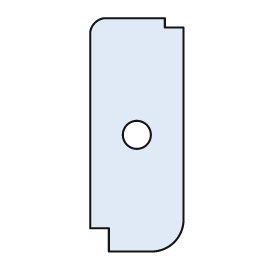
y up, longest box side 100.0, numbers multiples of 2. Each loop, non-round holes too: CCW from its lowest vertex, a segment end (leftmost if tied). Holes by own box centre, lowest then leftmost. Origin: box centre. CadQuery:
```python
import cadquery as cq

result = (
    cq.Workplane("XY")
    .moveTo(-12.0, -50.0)
    .lineTo(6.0, -50.0)
    .threePointArc((16.0, -46.0), (20.0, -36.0))
    .lineTo(20.0, 46.0)
    .lineTo(12.0, 46.0)
    .lineTo(12.0, 50.0)
    .lineTo(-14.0, 50.0)
    .threePointArc((-18.0, 48.0), (-20.0, 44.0))
    .lineTo(-20.0, -40.0)
    .lineTo(-12.0, -40.0)
    .close()
    .moveTo(0.0, 0.0)
    .circle(6.0)
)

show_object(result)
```